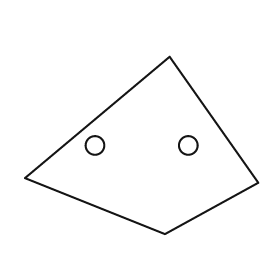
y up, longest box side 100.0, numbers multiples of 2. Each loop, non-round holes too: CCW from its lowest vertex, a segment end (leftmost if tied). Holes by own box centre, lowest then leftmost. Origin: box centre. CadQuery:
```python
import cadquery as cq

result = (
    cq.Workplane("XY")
    .moveTo(10.0, -38.0)
    .lineTo(50.0, -16.0)
    .lineTo(12.0, 38.0)
    .lineTo(-50.0, -14.0)
    .close()
    .moveTo(-20.0, 0.0)
    .circle(4.0)
    .moveTo(20.0, 0.0)
    .circle(4.0)
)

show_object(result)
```